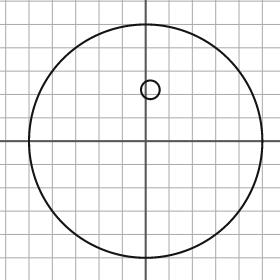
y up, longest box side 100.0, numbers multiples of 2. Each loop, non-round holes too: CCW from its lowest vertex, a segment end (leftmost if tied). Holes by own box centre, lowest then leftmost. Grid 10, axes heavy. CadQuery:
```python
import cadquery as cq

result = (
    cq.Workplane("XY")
    .moveTo(0.0, 0.0)
    .circle(50.0)
    .moveTo(2.0, 22.0)
    .circle(4.0)
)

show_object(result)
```